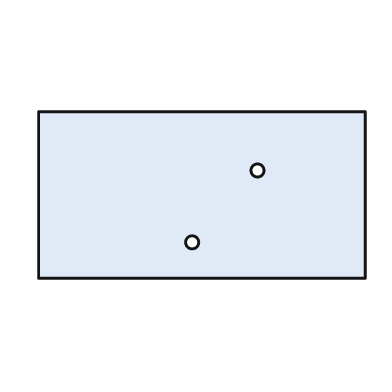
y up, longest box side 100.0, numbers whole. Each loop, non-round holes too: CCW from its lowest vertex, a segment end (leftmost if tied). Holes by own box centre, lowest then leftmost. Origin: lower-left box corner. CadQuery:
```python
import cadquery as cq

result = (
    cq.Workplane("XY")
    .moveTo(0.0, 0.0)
    .lineTo(100.0, 0.0)
    .lineTo(100.0, 51.0)
    .lineTo(0.0, 51.0)
    .close()
    .moveTo(47.0, 11.0)
    .circle(2.0)
    .moveTo(67.0, 33.0)
    .circle(2.0)
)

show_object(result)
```